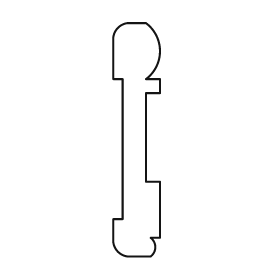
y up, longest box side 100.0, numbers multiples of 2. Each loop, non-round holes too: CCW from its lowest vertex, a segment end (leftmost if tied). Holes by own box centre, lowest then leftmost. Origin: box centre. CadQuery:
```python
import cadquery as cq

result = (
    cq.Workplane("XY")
    .moveTo(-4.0, -50.0)
    .lineTo(6.0, -50.0)
    .threePointArc((8.0, -46.0), (6.0, -42.0))
    .lineTo(10.0, -42.0)
    .lineTo(10.0, -18.0)
    .lineTo(4.0, -18.0)
    .lineTo(4.0, 20.0)
    .lineTo(10.0, 20.0)
    .lineTo(10.0, 26.0)
    .lineTo(4.0, 26.0)
    .threePointArc((10.0, 38.0), (4.0, 50.0))
    .lineTo(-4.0, 50.0)
    .threePointArc((-8.0, 48.0), (-10.0, 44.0))
    .lineTo(-10.0, 26.0)
    .lineTo(-6.0, 26.0)
    .lineTo(-6.0, -34.0)
    .lineTo(-10.0, -34.0)
    .lineTo(-10.0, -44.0)
    .threePointArc((-8.0, -48.0), (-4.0, -50.0))
    .close()
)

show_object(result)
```